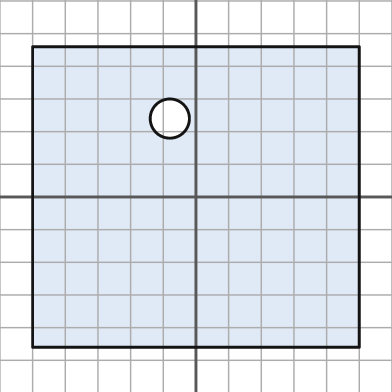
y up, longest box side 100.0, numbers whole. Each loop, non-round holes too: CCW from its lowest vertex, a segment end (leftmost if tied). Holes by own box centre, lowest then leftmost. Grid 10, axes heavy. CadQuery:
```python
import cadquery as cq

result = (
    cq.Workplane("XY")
    .moveTo(-50.0, -46.0)
    .lineTo(50.0, -46.0)
    .lineTo(50.0, 46.0)
    .lineTo(-50.0, 46.0)
    .close()
    .moveTo(-8.0, 24.0)
    .circle(6.0)
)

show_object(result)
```